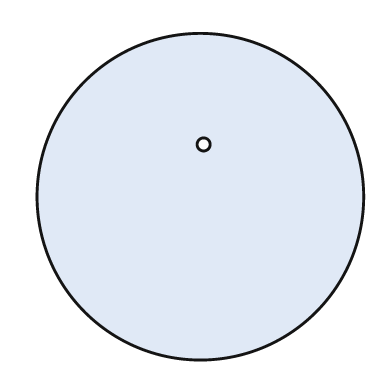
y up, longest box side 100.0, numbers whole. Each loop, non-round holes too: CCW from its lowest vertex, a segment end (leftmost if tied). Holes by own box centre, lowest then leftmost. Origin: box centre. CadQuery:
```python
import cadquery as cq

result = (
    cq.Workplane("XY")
    .moveTo(0.0, 0.0)
    .circle(50.0)
    .moveTo(1.0, 16.0)
    .circle(2.0)
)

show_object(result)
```